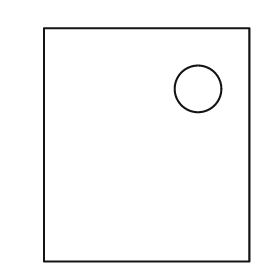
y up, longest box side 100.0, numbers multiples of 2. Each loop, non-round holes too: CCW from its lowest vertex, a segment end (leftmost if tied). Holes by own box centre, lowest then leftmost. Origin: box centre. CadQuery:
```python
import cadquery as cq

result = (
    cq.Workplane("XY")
    .moveTo(-44.0, -50.0)
    .lineTo(44.0, -50.0)
    .lineTo(44.0, 50.0)
    .lineTo(-44.0, 50.0)
    .close()
    .moveTo(22.0, 24.0)
    .circle(10.0)
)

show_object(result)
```